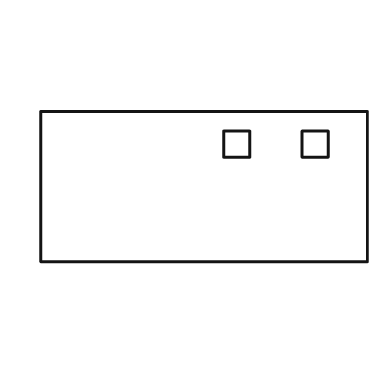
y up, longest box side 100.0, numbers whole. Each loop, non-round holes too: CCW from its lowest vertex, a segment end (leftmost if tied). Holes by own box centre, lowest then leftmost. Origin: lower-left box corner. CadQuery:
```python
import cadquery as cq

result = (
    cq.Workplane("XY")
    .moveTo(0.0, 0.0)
    .lineTo(100.0, 0.0)
    .lineTo(100.0, 46.0)
    .lineTo(0.0, 46.0)
    .close()
    .moveTo(56.0, 32.0)
    .lineTo(64.0, 32.0)
    .lineTo(64.0, 40.0)
    .lineTo(56.0, 40.0)
    .close()
    .moveTo(80.0, 32.0)
    .lineTo(88.0, 32.0)
    .lineTo(88.0, 40.0)
    .lineTo(80.0, 40.0)
    .close()
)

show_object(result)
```